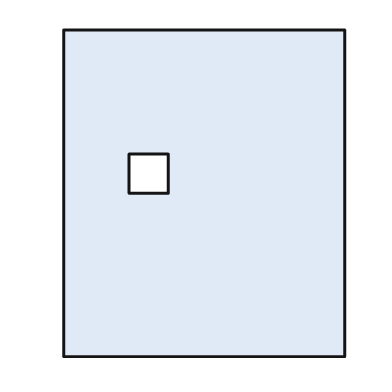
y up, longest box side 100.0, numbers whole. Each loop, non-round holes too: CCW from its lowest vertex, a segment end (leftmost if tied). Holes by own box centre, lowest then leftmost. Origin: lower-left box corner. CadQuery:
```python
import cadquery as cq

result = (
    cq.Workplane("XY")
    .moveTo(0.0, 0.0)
    .lineTo(86.0, 0.0)
    .lineTo(86.0, 100.0)
    .lineTo(0.0, 100.0)
    .close()
    .moveTo(20.0, 50.0)
    .lineTo(32.0, 50.0)
    .lineTo(32.0, 62.0)
    .lineTo(20.0, 62.0)
    .close()
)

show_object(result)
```